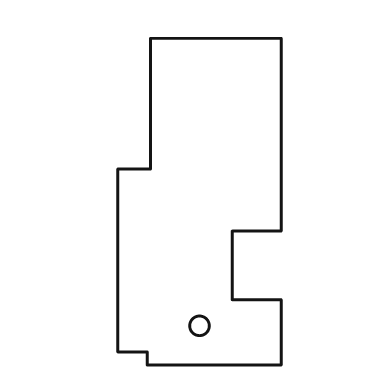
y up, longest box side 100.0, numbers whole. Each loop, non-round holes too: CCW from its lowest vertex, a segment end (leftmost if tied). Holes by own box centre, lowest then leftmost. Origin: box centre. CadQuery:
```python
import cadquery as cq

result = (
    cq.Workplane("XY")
    .moveTo(-16.0, -50.0)
    .lineTo(25.0, -50.0)
    .lineTo(25.0, -30.0)
    .lineTo(10.0, -30.0)
    .lineTo(10.0, -9.0)
    .lineTo(25.0, -9.0)
    .lineTo(25.0, 50.0)
    .lineTo(-15.0, 50.0)
    .lineTo(-15.0, 10.0)
    .lineTo(-25.0, 10.0)
    .lineTo(-25.0, -46.0)
    .lineTo(-16.0, -46.0)
    .close()
    .moveTo(0.0, -38.0)
    .circle(3.0)
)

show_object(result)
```